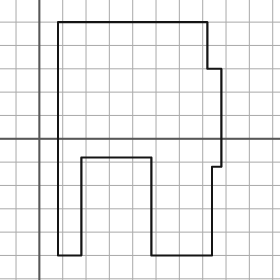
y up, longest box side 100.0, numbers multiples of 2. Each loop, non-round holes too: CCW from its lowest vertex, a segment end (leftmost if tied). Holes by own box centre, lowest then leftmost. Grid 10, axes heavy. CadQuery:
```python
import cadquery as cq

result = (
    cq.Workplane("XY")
    .moveTo(8.0, -50.0)
    .lineTo(18.0, -50.0)
    .lineTo(18.0, -8.0)
    .lineTo(48.0, -8.0)
    .lineTo(48.0, -50.0)
    .lineTo(74.0, -50.0)
    .lineTo(74.0, -12.0)
    .lineTo(78.0, -12.0)
    .lineTo(78.0, 30.0)
    .lineTo(72.0, 30.0)
    .lineTo(72.0, 50.0)
    .lineTo(8.0, 50.0)
    .close()
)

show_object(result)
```